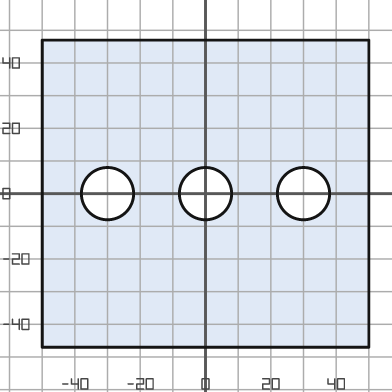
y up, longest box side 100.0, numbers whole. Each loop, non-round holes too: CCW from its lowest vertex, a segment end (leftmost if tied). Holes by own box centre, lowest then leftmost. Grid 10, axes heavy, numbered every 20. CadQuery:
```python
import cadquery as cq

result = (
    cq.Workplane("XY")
    .moveTo(-50.0, -47.0)
    .lineTo(50.0, -47.0)
    .lineTo(50.0, 47.0)
    .lineTo(-50.0, 47.0)
    .close()
    .moveTo(-30.0, 0.0)
    .circle(8.0)
    .moveTo(0.0, 0.0)
    .circle(8.0)
    .moveTo(30.0, 0.0)
    .circle(8.0)
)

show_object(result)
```